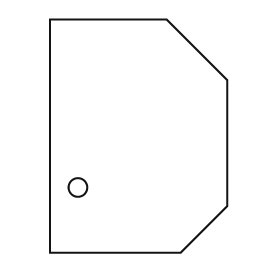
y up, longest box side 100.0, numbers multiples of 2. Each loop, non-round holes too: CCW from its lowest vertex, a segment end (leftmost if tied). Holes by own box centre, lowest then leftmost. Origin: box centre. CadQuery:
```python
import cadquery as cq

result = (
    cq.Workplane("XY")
    .moveTo(-38.0, -50.0)
    .lineTo(18.0, -50.0)
    .lineTo(38.0, -30.0)
    .lineTo(38.0, 24.0)
    .lineTo(12.0, 50.0)
    .lineTo(-38.0, 50.0)
    .close()
    .moveTo(-26.0, -22.0)
    .circle(4.0)
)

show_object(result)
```